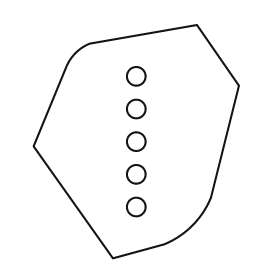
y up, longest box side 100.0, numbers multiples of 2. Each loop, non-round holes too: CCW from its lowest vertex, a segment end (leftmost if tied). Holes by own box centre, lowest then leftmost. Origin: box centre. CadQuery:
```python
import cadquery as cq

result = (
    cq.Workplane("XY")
    .moveTo(-10.0, -50.0)
    .lineTo(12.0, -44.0)
    .threePointArc((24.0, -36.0), (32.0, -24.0))
    .lineTo(44.0, 24.0)
    .lineTo(26.0, 50.0)
    .lineTo(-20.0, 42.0)
    .threePointArc((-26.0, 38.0), (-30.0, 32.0))
    .lineTo(-44.0, -2.0)
    .close()
    .moveTo(0.0, -28.0)
    .circle(4.0)
    .moveTo(0.0, -14.0)
    .circle(4.0)
    .moveTo(0.0, 0.0)
    .circle(4.0)
    .moveTo(0.0, 14.0)
    .circle(4.0)
    .moveTo(0.0, 28.0)
    .circle(4.0)
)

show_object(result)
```